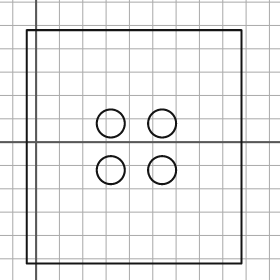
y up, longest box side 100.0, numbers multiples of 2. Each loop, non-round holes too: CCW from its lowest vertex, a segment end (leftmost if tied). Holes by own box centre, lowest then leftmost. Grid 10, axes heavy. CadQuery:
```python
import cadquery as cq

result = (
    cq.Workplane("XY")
    .moveTo(-4.0, -52.0)
    .lineTo(88.0, -52.0)
    .lineTo(88.0, 48.0)
    .lineTo(-4.0, 48.0)
    .close()
    .moveTo(32.0, -12.0)
    .circle(6.0)
    .moveTo(54.0, -12.0)
    .circle(6.0)
    .moveTo(32.0, 8.0)
    .circle(6.0)
    .moveTo(54.0, 8.0)
    .circle(6.0)
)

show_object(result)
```